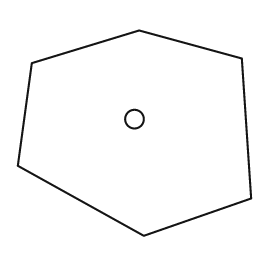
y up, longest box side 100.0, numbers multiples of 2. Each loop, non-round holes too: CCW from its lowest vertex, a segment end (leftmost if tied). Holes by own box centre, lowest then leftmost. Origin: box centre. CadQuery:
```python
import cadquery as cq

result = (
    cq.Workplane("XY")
    .moveTo(4.0, -44.0)
    .lineTo(50.0, -28.0)
    .lineTo(46.0, 32.0)
    .lineTo(2.0, 44.0)
    .lineTo(-44.0, 30.0)
    .lineTo(-50.0, -14.0)
    .close()
    .moveTo(0.0, 6.0)
    .circle(4.0)
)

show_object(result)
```